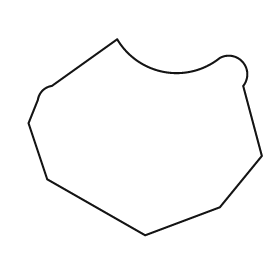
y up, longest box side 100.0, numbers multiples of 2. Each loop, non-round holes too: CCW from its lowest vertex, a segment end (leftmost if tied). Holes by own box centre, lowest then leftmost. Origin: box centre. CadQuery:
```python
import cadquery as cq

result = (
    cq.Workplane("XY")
    .moveTo(0.0, -42.0)
    .lineTo(32.0, -30.0)
    .lineTo(50.0, -8.0)
    .lineTo(42.0, 22.0)
    .threePointArc((42.0, 32.0), (32.0, 34.0))
    .threePointArc((8.0, 28.0), (-12.0, 42.0))
    .lineTo(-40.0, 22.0)
    .threePointArc((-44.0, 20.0), (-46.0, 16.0))
    .lineTo(-50.0, 6.0)
    .lineTo(-42.0, -18.0)
    .close()
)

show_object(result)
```